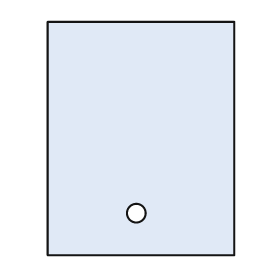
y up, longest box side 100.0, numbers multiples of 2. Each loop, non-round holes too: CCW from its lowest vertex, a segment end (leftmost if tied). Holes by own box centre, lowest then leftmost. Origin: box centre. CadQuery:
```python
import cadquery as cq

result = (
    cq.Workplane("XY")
    .moveTo(-40.0, -50.0)
    .lineTo(40.0, -50.0)
    .lineTo(40.0, 50.0)
    .lineTo(-40.0, 50.0)
    .close()
    .moveTo(-2.0, -32.0)
    .circle(4.0)
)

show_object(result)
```